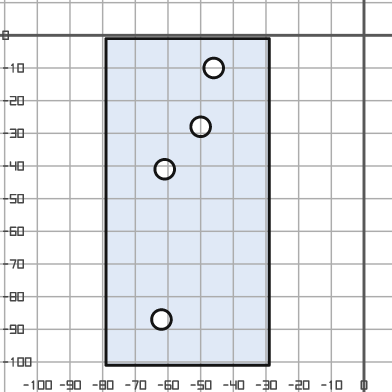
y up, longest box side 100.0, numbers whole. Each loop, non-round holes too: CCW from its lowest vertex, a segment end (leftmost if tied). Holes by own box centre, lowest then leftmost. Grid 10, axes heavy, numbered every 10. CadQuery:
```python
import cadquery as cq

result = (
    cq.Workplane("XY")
    .moveTo(-79.0, -101.0)
    .lineTo(-29.0, -101.0)
    .lineTo(-29.0, -1.0)
    .lineTo(-79.0, -1.0)
    .close()
    .moveTo(-62.0, -87.0)
    .circle(3.0)
    .moveTo(-61.0, -41.0)
    .circle(3.0)
    .moveTo(-50.0, -28.0)
    .circle(3.0)
    .moveTo(-46.0, -10.0)
    .circle(3.0)
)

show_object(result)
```